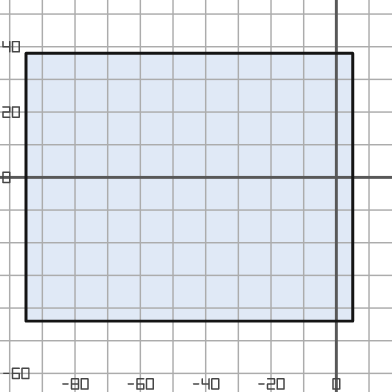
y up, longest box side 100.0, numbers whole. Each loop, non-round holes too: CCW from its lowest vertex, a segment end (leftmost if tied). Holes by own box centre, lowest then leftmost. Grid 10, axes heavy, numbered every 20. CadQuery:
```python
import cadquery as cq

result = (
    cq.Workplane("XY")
    .moveTo(-95.0, -44.0)
    .lineTo(5.0, -44.0)
    .lineTo(5.0, 38.0)
    .lineTo(-95.0, 38.0)
    .close()
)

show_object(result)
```